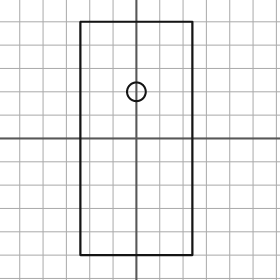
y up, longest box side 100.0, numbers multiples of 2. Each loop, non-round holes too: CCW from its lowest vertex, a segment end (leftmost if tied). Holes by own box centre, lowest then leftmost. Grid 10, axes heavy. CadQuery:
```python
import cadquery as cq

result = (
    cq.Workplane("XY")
    .moveTo(-24.0, -50.0)
    .lineTo(24.0, -50.0)
    .lineTo(24.0, 50.0)
    .lineTo(-24.0, 50.0)
    .close()
    .moveTo(0.0, 20.0)
    .circle(4.0)
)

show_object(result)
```